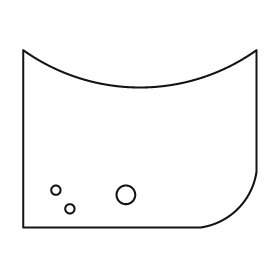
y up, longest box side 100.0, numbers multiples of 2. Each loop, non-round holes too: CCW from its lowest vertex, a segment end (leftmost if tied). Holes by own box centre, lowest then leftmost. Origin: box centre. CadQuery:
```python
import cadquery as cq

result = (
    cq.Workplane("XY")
    .moveTo(-50.0, -38.0)
    .lineTo(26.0, -38.0)
    .threePointArc((42.0, -30.0), (50.0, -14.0))
    .lineTo(50.0, 38.0)
    .threePointArc((0.0, 22.0), (-50.0, 38.0))
    .close()
    .moveTo(-30.0, -30.0)
    .circle(2.0)
    .moveTo(-6.0, -24.0)
    .circle(4.0)
    .moveTo(-36.0, -22.0)
    .circle(2.0)
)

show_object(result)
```